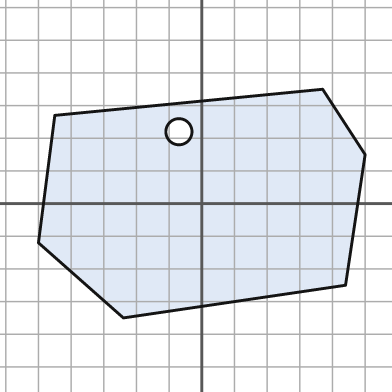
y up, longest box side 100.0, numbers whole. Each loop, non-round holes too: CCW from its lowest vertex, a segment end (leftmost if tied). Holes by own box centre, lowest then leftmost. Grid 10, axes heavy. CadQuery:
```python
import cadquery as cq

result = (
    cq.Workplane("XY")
    .moveTo(-24.0, -35.0)
    .lineTo(44.0, -25.0)
    .lineTo(50.0, 15.0)
    .lineTo(37.0, 35.0)
    .lineTo(-45.0, 27.0)
    .lineTo(-50.0, -12.0)
    .close()
    .moveTo(-7.0, 22.0)
    .circle(4.0)
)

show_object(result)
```